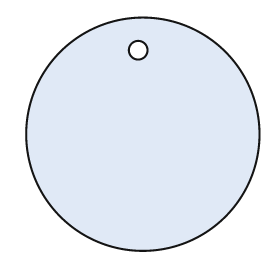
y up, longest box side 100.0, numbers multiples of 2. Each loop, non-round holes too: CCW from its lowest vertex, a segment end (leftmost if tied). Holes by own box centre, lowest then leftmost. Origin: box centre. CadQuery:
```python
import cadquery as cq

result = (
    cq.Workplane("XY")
    .moveTo(0.0, 0.0)
    .circle(50.0)
    .moveTo(-2.0, 36.0)
    .circle(4.0)
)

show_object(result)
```